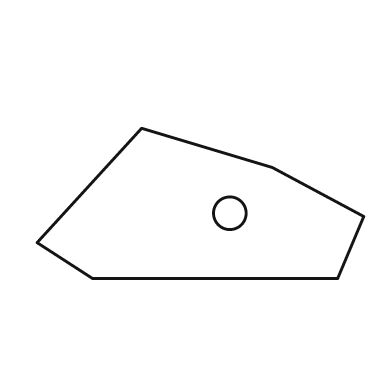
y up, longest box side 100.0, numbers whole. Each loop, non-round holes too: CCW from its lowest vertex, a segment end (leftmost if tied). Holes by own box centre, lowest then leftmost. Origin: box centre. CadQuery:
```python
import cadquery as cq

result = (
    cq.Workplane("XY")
    .moveTo(-33.0, -23.0)
    .lineTo(42.0, -23.0)
    .lineTo(50.0, -4.0)
    .lineTo(22.0, 11.0)
    .lineTo(-18.0, 23.0)
    .lineTo(-50.0, -12.0)
    .close()
    .moveTo(9.0, -3.0)
    .circle(5.0)
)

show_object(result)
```